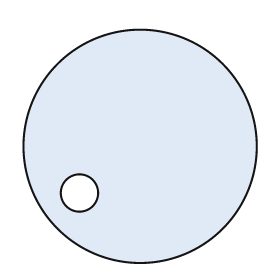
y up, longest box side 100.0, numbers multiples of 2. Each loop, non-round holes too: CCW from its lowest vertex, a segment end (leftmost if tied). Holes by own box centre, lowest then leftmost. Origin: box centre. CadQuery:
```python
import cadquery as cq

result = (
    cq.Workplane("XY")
    .moveTo(0.0, 0.0)
    .circle(50.0)
    .moveTo(-26.0, -20.0)
    .circle(8.0)
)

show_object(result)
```